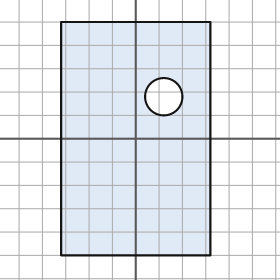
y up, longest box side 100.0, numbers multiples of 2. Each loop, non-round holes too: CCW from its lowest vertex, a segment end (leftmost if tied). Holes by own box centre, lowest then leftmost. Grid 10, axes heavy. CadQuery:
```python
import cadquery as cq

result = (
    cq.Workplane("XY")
    .moveTo(-32.0, -50.0)
    .lineTo(32.0, -50.0)
    .lineTo(32.0, 50.0)
    .lineTo(-32.0, 50.0)
    .close()
    .moveTo(12.0, 18.0)
    .circle(8.0)
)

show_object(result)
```